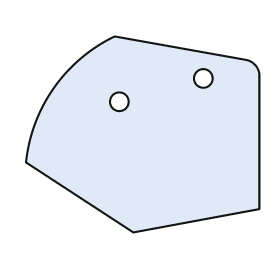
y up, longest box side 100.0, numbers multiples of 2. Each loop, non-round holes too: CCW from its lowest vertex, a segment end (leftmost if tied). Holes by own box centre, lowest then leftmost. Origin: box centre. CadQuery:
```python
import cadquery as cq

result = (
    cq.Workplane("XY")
    .moveTo(-4.0, -42.0)
    .lineTo(50.0, -32.0)
    .lineTo(50.0, 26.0)
    .threePointArc((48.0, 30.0), (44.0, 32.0))
    .lineTo(-12.0, 42.0)
    .threePointArc((-38.0, 20.0), (-50.0, -12.0))
    .close()
    .moveTo(-10.0, 14.0)
    .circle(4.0)
    .moveTo(26.0, 24.0)
    .circle(4.0)
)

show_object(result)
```